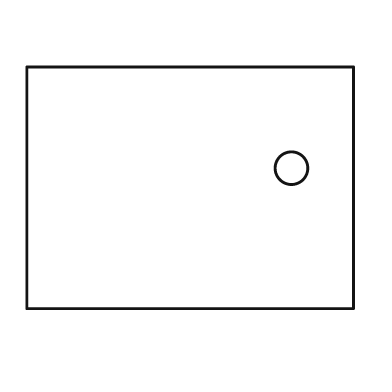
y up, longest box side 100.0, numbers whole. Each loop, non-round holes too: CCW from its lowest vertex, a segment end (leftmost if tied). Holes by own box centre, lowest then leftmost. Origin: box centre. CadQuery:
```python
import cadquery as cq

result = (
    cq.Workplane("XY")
    .moveTo(-50.0, -37.0)
    .lineTo(50.0, -37.0)
    .lineTo(50.0, 37.0)
    .lineTo(-50.0, 37.0)
    .close()
    .moveTo(31.0, 6.0)
    .circle(5.0)
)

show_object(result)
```